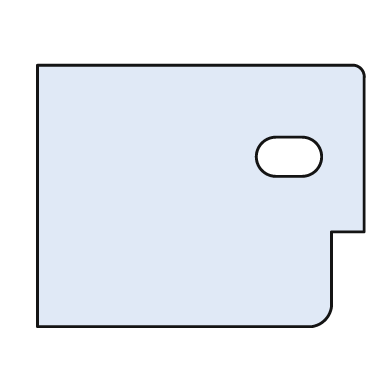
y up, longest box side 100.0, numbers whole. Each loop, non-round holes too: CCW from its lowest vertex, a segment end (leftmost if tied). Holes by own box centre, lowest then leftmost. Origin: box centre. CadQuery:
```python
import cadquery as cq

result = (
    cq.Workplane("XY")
    .moveTo(-50.0, -40.0)
    .lineTo(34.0, -40.0)
    .threePointArc((38.0, -38.0), (40.0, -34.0))
    .lineTo(40.0, -11.0)
    .lineTo(50.0, -11.0)
    .lineTo(50.0, 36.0)
    .threePointArc((49.0, 39.0), (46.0, 40.0))
    .lineTo(-50.0, 40.0)
    .close()
    .moveTo(23.0, 6.0)
    .lineTo(31.0, 6.0)
    .threePointArc((37.0, 12.0), (31.0, 18.0))
    .lineTo(23.0, 18.0)
    .threePointArc((17.0, 12.0), (23.0, 6.0))
    .close()
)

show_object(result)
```